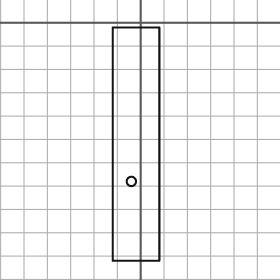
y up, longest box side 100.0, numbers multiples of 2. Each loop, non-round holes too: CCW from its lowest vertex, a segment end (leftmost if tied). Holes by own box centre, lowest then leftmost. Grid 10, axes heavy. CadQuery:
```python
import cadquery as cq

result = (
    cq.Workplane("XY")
    .moveTo(-12.0, -102.0)
    .lineTo(8.0, -102.0)
    .lineTo(8.0, -2.0)
    .lineTo(-12.0, -2.0)
    .close()
    .moveTo(-4.0, -68.0)
    .circle(2.0)
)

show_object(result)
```